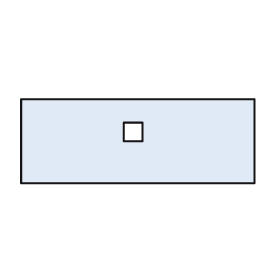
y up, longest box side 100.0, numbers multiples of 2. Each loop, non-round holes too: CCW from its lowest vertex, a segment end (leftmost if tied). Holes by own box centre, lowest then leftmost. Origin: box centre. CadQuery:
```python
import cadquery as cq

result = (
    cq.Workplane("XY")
    .moveTo(-50.0, -18.0)
    .lineTo(50.0, -18.0)
    .lineTo(50.0, 18.0)
    .lineTo(-50.0, 18.0)
    .close()
    .moveTo(-6.0, 0.0)
    .lineTo(2.0, 0.0)
    .lineTo(2.0, 8.0)
    .lineTo(-6.0, 8.0)
    .close()
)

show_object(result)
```